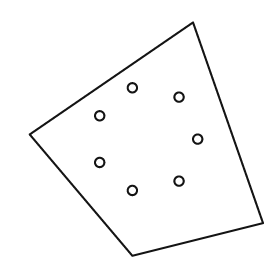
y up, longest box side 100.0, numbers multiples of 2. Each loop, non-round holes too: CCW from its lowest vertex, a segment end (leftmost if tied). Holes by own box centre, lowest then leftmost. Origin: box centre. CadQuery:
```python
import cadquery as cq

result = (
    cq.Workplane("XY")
    .moveTo(-6.0, -50.0)
    .lineTo(50.0, -36.0)
    .lineTo(20.0, 50.0)
    .lineTo(-50.0, 2.0)
    .close()
    .moveTo(-6.0, -22.0)
    .circle(2.0)
    .moveTo(14.0, -18.0)
    .circle(2.0)
    .moveTo(-20.0, -10.0)
    .circle(2.0)
    .moveTo(22.0, 0.0)
    .circle(2.0)
    .moveTo(-20.0, 10.0)
    .circle(2.0)
    .moveTo(14.0, 18.0)
    .circle(2.0)
    .moveTo(-6.0, 22.0)
    .circle(2.0)
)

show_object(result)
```